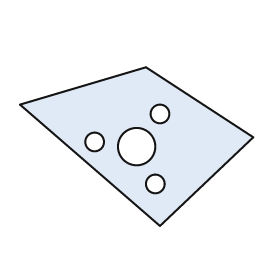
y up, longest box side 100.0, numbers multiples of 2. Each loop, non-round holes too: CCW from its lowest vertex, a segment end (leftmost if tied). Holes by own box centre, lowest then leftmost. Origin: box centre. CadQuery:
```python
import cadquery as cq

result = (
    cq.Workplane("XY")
    .moveTo(10.0, -34.0)
    .lineTo(50.0, 4.0)
    .lineTo(4.0, 34.0)
    .lineTo(-50.0, 18.0)
    .close()
    .moveTo(8.0, -16.0)
    .circle(4.0)
    .moveTo(0.0, 0.0)
    .circle(8.0)
    .moveTo(-18.0, 2.0)
    .circle(4.0)
    .moveTo(10.0, 14.0)
    .circle(4.0)
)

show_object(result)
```